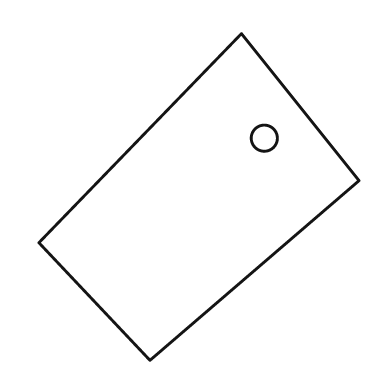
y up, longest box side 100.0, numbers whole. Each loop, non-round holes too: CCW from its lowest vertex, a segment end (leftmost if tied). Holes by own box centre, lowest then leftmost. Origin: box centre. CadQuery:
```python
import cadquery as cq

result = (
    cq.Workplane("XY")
    .moveTo(-15.0, -50.0)
    .lineTo(49.0, 5.0)
    .lineTo(13.0, 50.0)
    .lineTo(-49.0, -14.0)
    .close()
    .moveTo(20.0, 18.0)
    .circle(4.0)
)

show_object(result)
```